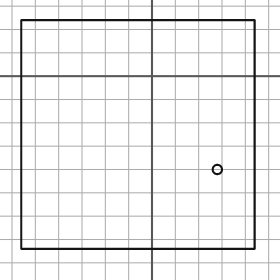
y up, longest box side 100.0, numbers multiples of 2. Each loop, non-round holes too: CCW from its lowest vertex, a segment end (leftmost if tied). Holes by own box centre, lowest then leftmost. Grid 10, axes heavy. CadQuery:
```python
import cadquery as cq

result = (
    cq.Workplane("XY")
    .moveTo(-56.0, -74.0)
    .lineTo(44.0, -74.0)
    .lineTo(44.0, 24.0)
    .lineTo(-56.0, 24.0)
    .close()
    .moveTo(28.0, -40.0)
    .circle(2.0)
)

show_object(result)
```